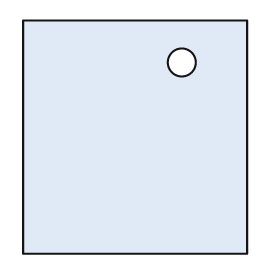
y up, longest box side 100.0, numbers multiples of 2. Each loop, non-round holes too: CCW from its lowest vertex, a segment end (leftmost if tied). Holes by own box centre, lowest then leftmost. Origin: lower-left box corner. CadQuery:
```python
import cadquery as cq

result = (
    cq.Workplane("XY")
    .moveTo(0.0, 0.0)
    .lineTo(96.0, 0.0)
    .lineTo(96.0, 100.0)
    .lineTo(0.0, 100.0)
    .close()
    .moveTo(68.0, 82.0)
    .circle(6.0)
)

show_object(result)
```